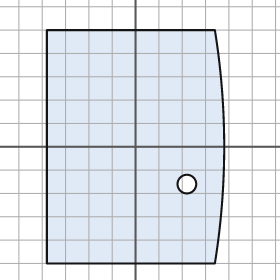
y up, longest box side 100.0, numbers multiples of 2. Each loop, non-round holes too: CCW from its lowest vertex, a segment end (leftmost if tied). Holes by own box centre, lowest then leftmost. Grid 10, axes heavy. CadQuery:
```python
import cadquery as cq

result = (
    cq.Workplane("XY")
    .moveTo(-38.0, -50.0)
    .lineTo(34.0, -50.0)
    .threePointArc((38.0, 0.0), (34.0, 50.0))
    .lineTo(-38.0, 50.0)
    .close()
    .moveTo(22.0, -16.0)
    .circle(4.0)
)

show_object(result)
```